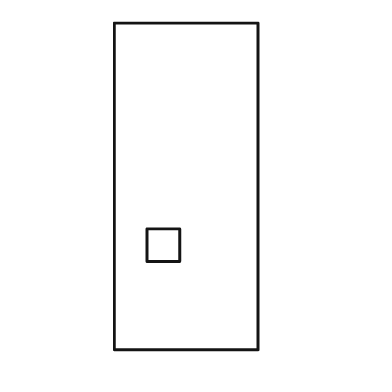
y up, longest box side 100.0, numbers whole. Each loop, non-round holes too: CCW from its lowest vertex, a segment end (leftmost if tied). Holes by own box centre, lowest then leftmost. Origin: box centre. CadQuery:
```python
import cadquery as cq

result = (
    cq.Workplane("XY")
    .moveTo(-22.0, -50.0)
    .lineTo(22.0, -50.0)
    .lineTo(22.0, 50.0)
    .lineTo(-22.0, 50.0)
    .close()
    .moveTo(-12.0, -23.0)
    .lineTo(-2.0, -23.0)
    .lineTo(-2.0, -13.0)
    .lineTo(-12.0, -13.0)
    .close()
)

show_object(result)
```